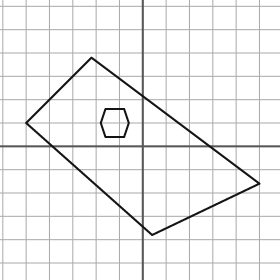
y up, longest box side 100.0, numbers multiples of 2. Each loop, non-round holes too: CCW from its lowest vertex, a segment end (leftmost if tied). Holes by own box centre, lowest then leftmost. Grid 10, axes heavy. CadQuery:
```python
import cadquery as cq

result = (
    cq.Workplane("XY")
    .moveTo(4.0, -38.0)
    .lineTo(50.0, -16.0)
    .lineTo(-22.0, 38.0)
    .lineTo(-50.0, 10.0)
    .close()
    .moveTo(-16.0, 4.0)
    .lineTo(-8.0, 4.0)
    .lineTo(-6.0, 10.0)
    .lineTo(-8.0, 16.0)
    .lineTo(-16.0, 16.0)
    .lineTo(-18.0, 10.0)
    .close()
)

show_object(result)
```